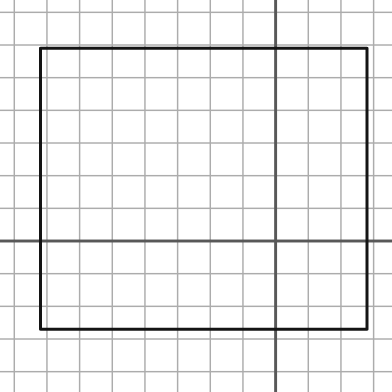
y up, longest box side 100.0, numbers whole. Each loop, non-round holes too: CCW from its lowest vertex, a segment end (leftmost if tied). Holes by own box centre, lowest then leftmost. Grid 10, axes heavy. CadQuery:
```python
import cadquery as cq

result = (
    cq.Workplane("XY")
    .moveTo(-72.0, -27.0)
    .lineTo(28.0, -27.0)
    .lineTo(28.0, 59.0)
    .lineTo(-72.0, 59.0)
    .close()
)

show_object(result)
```